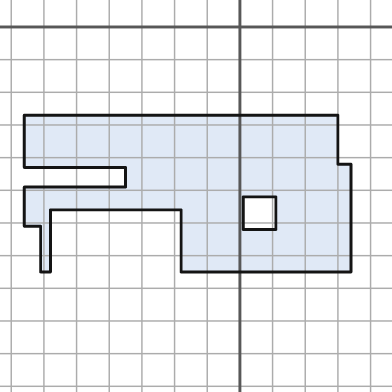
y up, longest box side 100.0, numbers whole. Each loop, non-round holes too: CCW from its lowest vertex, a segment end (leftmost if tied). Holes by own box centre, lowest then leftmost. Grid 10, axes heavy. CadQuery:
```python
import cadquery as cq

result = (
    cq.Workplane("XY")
    .moveTo(-61.0, -75.0)
    .lineTo(-58.0, -75.0)
    .lineTo(-58.0, -56.0)
    .lineTo(-18.0, -56.0)
    .lineTo(-18.0, -75.0)
    .lineTo(34.0, -75.0)
    .lineTo(34.0, -42.0)
    .lineTo(30.0, -42.0)
    .lineTo(30.0, -27.0)
    .lineTo(-66.0, -27.0)
    .lineTo(-66.0, -43.0)
    .lineTo(-35.0, -43.0)
    .lineTo(-35.0, -49.0)
    .lineTo(-66.0, -49.0)
    .lineTo(-66.0, -61.0)
    .lineTo(-61.0, -61.0)
    .close()
    .moveTo(1.0, -62.0)
    .lineTo(11.0, -62.0)
    .lineTo(11.0, -52.0)
    .lineTo(1.0, -52.0)
    .close()
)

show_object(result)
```